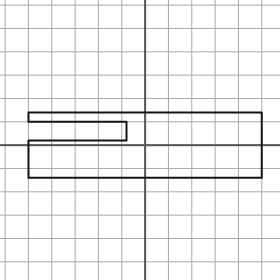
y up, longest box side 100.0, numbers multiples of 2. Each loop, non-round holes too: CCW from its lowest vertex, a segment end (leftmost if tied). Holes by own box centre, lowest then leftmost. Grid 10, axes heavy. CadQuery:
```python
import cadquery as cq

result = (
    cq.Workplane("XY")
    .moveTo(-50.0, -14.0)
    .lineTo(50.0, -14.0)
    .lineTo(50.0, 14.0)
    .lineTo(-50.0, 14.0)
    .lineTo(-50.0, 10.0)
    .lineTo(-8.0, 10.0)
    .lineTo(-8.0, 2.0)
    .lineTo(-50.0, 2.0)
    .close()
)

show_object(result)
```